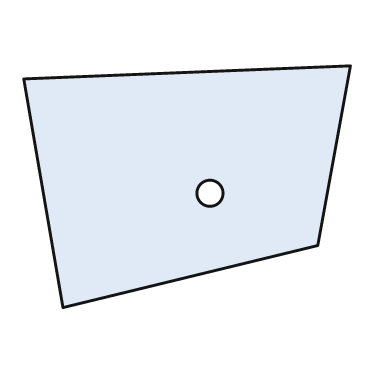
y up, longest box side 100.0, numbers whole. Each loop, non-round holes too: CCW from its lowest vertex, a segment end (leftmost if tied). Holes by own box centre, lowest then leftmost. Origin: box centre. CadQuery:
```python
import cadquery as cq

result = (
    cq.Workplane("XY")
    .moveTo(-38.0, -37.0)
    .lineTo(40.0, -18.0)
    .lineTo(50.0, 37.0)
    .lineTo(-50.0, 33.0)
    .close()
    .moveTo(7.0, -2.0)
    .circle(4.0)
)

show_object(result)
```